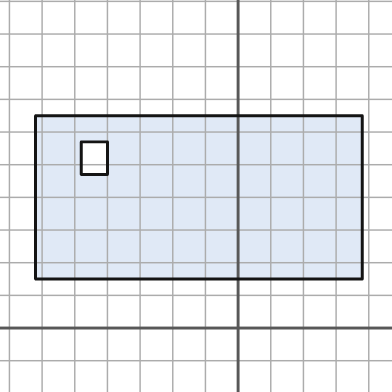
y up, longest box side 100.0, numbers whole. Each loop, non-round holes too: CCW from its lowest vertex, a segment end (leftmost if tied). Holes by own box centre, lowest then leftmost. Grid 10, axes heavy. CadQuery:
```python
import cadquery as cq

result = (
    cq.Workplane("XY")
    .moveTo(-62.0, 15.0)
    .lineTo(38.0, 15.0)
    .lineTo(38.0, 65.0)
    .lineTo(-62.0, 65.0)
    .close()
    .moveTo(-48.0, 47.0)
    .lineTo(-40.0, 47.0)
    .lineTo(-40.0, 57.0)
    .lineTo(-48.0, 57.0)
    .close()
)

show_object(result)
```